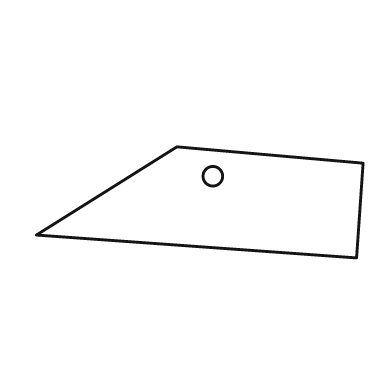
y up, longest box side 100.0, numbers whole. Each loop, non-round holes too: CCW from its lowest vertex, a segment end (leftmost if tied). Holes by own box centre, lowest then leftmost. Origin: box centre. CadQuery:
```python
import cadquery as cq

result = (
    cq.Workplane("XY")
    .moveTo(48.0, -17.0)
    .lineTo(50.0, 12.0)
    .lineTo(-7.0, 17.0)
    .lineTo(-50.0, -10.0)
    .close()
    .moveTo(4.0, 8.0)
    .circle(3.0)
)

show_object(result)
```